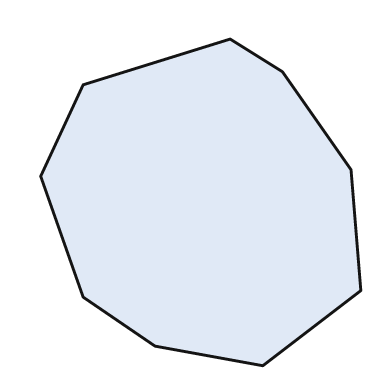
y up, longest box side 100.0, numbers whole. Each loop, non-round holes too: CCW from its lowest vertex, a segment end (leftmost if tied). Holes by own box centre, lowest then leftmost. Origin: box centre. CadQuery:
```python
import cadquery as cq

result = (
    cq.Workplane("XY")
    .moveTo(19.0, -50.0)
    .lineTo(49.0, -27.0)
    .lineTo(46.0, 10.0)
    .lineTo(25.0, 40.0)
    .lineTo(9.0, 50.0)
    .lineTo(-36.0, 36.0)
    .lineTo(-49.0, 8.0)
    .lineTo(-36.0, -29.0)
    .lineTo(-14.0, -44.0)
    .close()
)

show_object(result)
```